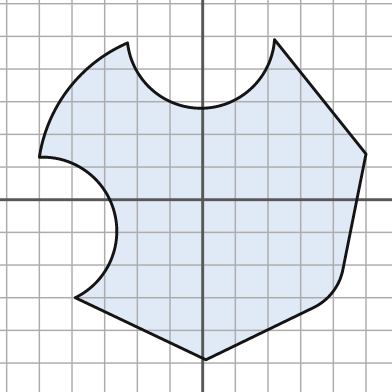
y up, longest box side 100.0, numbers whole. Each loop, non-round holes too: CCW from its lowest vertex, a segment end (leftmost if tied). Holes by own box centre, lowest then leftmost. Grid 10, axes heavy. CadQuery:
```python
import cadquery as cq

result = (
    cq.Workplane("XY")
    .moveTo(1.0, -49.0)
    .lineTo(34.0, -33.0)
    .threePointArc((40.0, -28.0), (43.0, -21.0))
    .lineTo(50.0, 14.0)
    .lineTo(22.0, 49.0)
    .threePointArc((0.0, 28.0), (-23.0, 48.0))
    .threePointArc((-41.0, 34.0), (-50.0, 13.0))
    .threePointArc((-27.0, -4.0), (-39.0, -30.0))
    .close()
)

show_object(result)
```